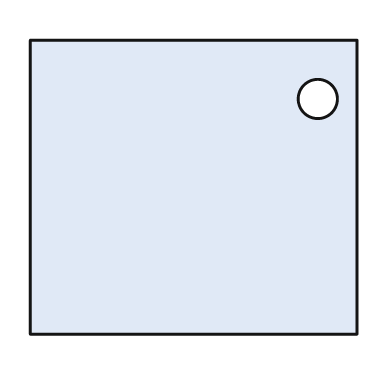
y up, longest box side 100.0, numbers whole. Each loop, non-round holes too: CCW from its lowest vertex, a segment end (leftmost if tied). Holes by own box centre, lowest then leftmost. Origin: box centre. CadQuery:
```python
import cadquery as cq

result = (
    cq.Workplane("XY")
    .moveTo(-50.0, -45.0)
    .lineTo(50.0, -45.0)
    .lineTo(50.0, 45.0)
    .lineTo(-50.0, 45.0)
    .close()
    .moveTo(38.0, 27.0)
    .circle(6.0)
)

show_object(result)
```